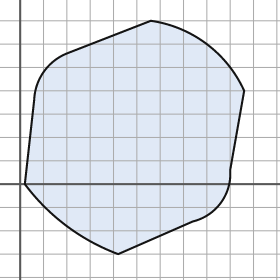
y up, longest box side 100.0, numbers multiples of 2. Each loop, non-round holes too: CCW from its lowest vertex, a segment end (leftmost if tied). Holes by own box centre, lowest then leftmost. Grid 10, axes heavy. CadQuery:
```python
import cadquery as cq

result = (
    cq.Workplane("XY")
    .moveTo(42.0, -30.0)
    .lineTo(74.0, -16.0)
    .threePointArc((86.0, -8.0), (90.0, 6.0))
    .lineTo(96.0, 40.0)
    .threePointArc((80.0, 60.0), (56.0, 70.0))
    .lineTo(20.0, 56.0)
    .threePointArc((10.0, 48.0), (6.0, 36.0))
    .lineTo(2.0, 0.0)
    .threePointArc((20.0, -18.0), (42.0, -30.0))
    .close()
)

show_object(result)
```